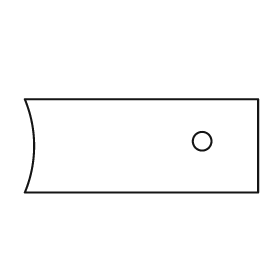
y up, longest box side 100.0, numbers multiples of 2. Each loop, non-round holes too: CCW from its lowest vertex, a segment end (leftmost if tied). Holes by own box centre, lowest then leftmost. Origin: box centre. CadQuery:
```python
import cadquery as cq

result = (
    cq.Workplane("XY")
    .moveTo(-50.0, -20.0)
    .lineTo(50.0, -20.0)
    .lineTo(50.0, 20.0)
    .lineTo(-50.0, 20.0)
    .threePointArc((-46.0, 0.0), (-50.0, -20.0))
    .close()
    .moveTo(26.0, 2.0)
    .circle(4.0)
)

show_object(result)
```